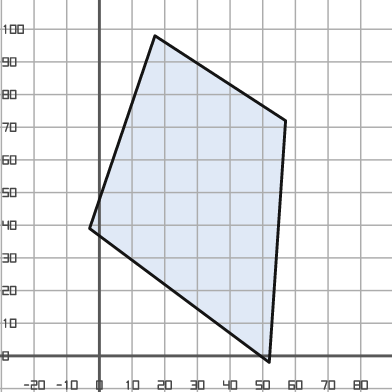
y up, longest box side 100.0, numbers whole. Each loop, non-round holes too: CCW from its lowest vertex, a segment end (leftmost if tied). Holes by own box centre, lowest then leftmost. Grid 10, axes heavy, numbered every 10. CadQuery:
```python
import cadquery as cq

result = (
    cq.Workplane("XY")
    .moveTo(52.0, -2.0)
    .lineTo(57.0, 72.0)
    .lineTo(17.0, 98.0)
    .lineTo(-3.0, 39.0)
    .close()
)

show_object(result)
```